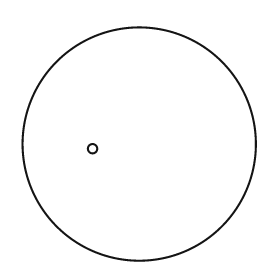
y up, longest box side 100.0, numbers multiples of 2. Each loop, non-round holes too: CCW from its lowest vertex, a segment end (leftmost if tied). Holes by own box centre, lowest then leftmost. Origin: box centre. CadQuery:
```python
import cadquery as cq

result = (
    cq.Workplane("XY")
    .moveTo(0.0, 0.0)
    .circle(50.0)
    .moveTo(-20.0, -2.0)
    .circle(2.0)
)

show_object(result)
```